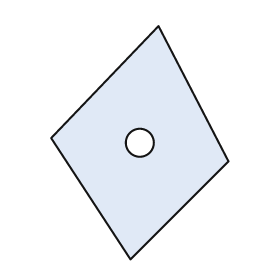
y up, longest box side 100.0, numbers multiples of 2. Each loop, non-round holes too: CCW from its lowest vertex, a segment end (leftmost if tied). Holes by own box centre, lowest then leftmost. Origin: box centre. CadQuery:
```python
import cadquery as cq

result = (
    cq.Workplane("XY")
    .moveTo(-4.0, -50.0)
    .lineTo(38.0, -8.0)
    .lineTo(8.0, 50.0)
    .lineTo(-38.0, 2.0)
    .close()
    .moveTo(0.0, 0.0)
    .circle(6.0)
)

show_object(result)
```